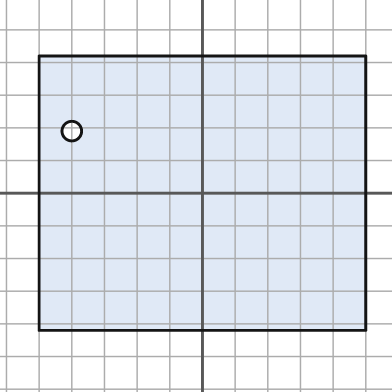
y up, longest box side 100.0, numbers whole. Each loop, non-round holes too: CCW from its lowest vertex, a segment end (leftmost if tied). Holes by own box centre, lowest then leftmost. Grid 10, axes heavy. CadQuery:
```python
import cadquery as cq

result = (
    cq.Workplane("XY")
    .moveTo(-50.0, -42.0)
    .lineTo(50.0, -42.0)
    .lineTo(50.0, 42.0)
    .lineTo(-50.0, 42.0)
    .close()
    .moveTo(-40.0, 19.0)
    .circle(3.0)
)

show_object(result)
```